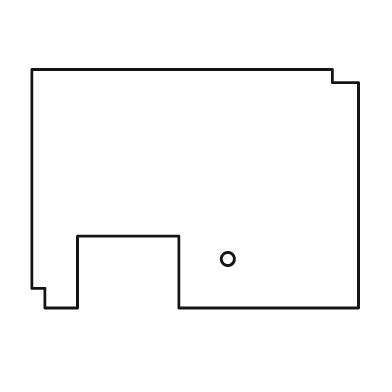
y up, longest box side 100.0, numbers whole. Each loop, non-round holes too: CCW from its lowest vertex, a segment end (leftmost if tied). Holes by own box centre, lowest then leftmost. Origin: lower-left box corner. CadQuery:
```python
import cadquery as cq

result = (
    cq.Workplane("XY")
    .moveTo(4.0, 0.0)
    .lineTo(14.0, 0.0)
    .lineTo(14.0, 22.0)
    .lineTo(45.0, 22.0)
    .lineTo(45.0, 0.0)
    .lineTo(100.0, 0.0)
    .lineTo(100.0, 69.0)
    .lineTo(92.0, 69.0)
    .lineTo(92.0, 73.0)
    .lineTo(0.0, 73.0)
    .lineTo(0.0, 6.0)
    .lineTo(4.0, 6.0)
    .close()
    .moveTo(60.0, 15.0)
    .circle(2.0)
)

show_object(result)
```